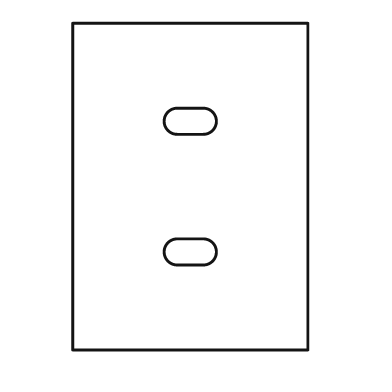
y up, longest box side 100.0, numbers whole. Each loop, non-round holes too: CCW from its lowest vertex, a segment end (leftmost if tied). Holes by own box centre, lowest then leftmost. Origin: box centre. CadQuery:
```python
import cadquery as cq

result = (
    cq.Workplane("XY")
    .moveTo(-36.0, -50.0)
    .lineTo(36.0, -50.0)
    .lineTo(36.0, 50.0)
    .lineTo(-36.0, 50.0)
    .close()
    .moveTo(-4.0, -24.0)
    .lineTo(4.0, -24.0)
    .threePointArc((8.0, -20.0), (4.0, -16.0))
    .lineTo(-4.0, -16.0)
    .threePointArc((-8.0, -20.0), (-4.0, -24.0))
    .close()
    .moveTo(-4.0, 16.0)
    .lineTo(4.0, 16.0)
    .threePointArc((8.0, 20.0), (4.0, 24.0))
    .lineTo(-4.0, 24.0)
    .threePointArc((-8.0, 20.0), (-4.0, 16.0))
    .close()
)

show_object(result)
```